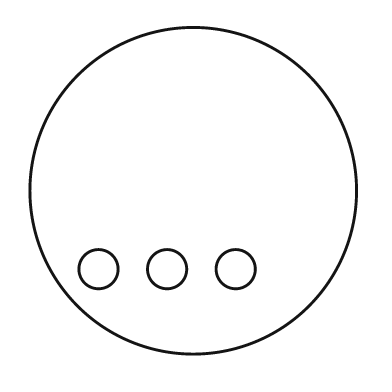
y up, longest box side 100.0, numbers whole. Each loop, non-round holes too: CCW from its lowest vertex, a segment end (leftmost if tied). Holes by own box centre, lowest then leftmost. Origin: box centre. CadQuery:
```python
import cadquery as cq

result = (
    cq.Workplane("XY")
    .moveTo(0.0, 0.0)
    .circle(50.0)
    .moveTo(-29.0, -24.0)
    .circle(6.0)
    .moveTo(-8.0, -24.0)
    .circle(6.0)
    .moveTo(13.0, -24.0)
    .circle(6.0)
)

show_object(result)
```